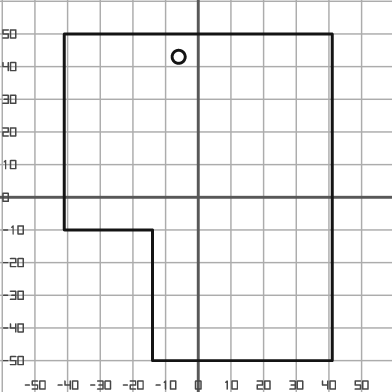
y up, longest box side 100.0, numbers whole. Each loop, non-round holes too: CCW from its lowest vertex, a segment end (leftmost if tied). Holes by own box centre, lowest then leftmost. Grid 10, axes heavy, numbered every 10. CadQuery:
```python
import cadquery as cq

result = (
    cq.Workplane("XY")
    .moveTo(-14.0, -50.0)
    .lineTo(41.0, -50.0)
    .lineTo(41.0, 50.0)
    .lineTo(-41.0, 50.0)
    .lineTo(-41.0, -10.0)
    .lineTo(-14.0, -10.0)
    .close()
    .moveTo(-6.0, 43.0)
    .circle(2.0)
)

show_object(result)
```